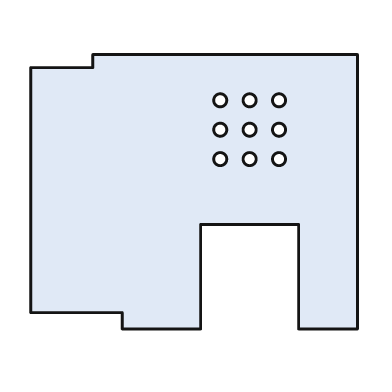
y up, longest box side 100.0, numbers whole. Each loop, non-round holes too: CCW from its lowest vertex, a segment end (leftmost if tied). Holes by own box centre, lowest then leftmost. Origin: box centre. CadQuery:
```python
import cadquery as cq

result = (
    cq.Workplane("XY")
    .moveTo(-22.0, -42.0)
    .lineTo(2.0, -42.0)
    .lineTo(2.0, -10.0)
    .lineTo(32.0, -10.0)
    .lineTo(32.0, -42.0)
    .lineTo(50.0, -42.0)
    .lineTo(50.0, 42.0)
    .lineTo(-31.0, 42.0)
    .lineTo(-31.0, 38.0)
    .lineTo(-50.0, 38.0)
    .lineTo(-50.0, -37.0)
    .lineTo(-22.0, -37.0)
    .close()
    .moveTo(8.0, 10.0)
    .circle(2.0)
    .moveTo(17.0, 10.0)
    .circle(2.0)
    .moveTo(26.0, 10.0)
    .circle(2.0)
    .moveTo(8.0, 19.0)
    .circle(2.0)
    .moveTo(17.0, 19.0)
    .circle(2.0)
    .moveTo(26.0, 19.0)
    .circle(2.0)
    .moveTo(8.0, 28.0)
    .circle(2.0)
    .moveTo(17.0, 28.0)
    .circle(2.0)
    .moveTo(26.0, 28.0)
    .circle(2.0)
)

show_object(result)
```